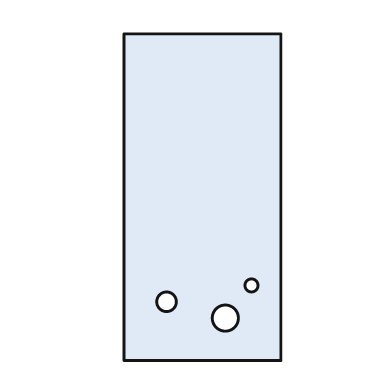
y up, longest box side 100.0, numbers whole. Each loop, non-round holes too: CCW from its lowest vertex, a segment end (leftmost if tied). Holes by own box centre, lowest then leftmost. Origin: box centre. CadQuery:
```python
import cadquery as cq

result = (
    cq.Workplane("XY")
    .moveTo(-24.0, -50.0)
    .lineTo(24.0, -50.0)
    .lineTo(24.0, 50.0)
    .lineTo(-24.0, 50.0)
    .close()
    .moveTo(7.0, -37.0)
    .circle(4.0)
    .moveTo(-11.0, -32.0)
    .circle(3.0)
    .moveTo(15.0, -27.0)
    .circle(2.0)
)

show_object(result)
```